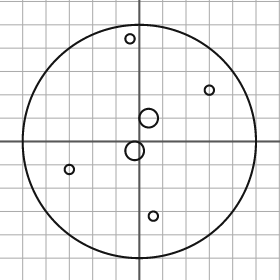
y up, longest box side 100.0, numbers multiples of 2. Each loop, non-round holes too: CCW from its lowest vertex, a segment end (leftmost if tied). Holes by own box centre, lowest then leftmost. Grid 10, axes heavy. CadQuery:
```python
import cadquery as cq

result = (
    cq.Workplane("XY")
    .moveTo(0.0, 0.0)
    .circle(50.0)
    .moveTo(6.0, -32.0)
    .circle(2.0)
    .moveTo(-30.0, -12.0)
    .circle(2.0)
    .moveTo(-2.0, -4.0)
    .circle(4.0)
    .moveTo(4.0, 10.0)
    .circle(4.0)
    .moveTo(30.0, 22.0)
    .circle(2.0)
    .moveTo(-4.0, 44.0)
    .circle(2.0)
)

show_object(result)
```